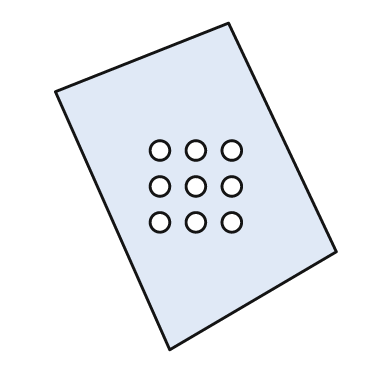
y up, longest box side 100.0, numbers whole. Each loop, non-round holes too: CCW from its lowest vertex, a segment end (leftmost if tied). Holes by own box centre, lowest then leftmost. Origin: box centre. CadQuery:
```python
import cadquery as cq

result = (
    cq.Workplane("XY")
    .moveTo(-8.0, -50.0)
    .lineTo(43.0, -20.0)
    .lineTo(10.0, 50.0)
    .lineTo(-43.0, 29.0)
    .close()
    .moveTo(-11.0, -11.0)
    .circle(3.0)
    .moveTo(0.0, -11.0)
    .circle(3.0)
    .moveTo(11.0, -11.0)
    .circle(3.0)
    .moveTo(-11.0, 0.0)
    .circle(3.0)
    .moveTo(0.0, 0.0)
    .circle(3.0)
    .moveTo(11.0, 0.0)
    .circle(3.0)
    .moveTo(-11.0, 11.0)
    .circle(3.0)
    .moveTo(0.0, 11.0)
    .circle(3.0)
    .moveTo(11.0, 11.0)
    .circle(3.0)
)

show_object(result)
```